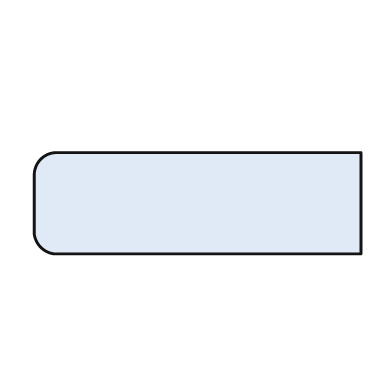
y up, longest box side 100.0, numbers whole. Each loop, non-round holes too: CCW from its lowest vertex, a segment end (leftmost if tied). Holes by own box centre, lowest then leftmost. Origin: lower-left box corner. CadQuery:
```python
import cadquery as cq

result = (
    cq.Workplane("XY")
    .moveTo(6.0, 0.0)
    .lineTo(100.0, 0.0)
    .lineTo(100.0, 31.0)
    .lineTo(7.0, 31.0)
    .threePointArc((2.0, 29.0), (0.0, 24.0))
    .lineTo(0.0, 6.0)
    .threePointArc((2.0, 2.0), (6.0, 0.0))
    .close()
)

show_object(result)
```